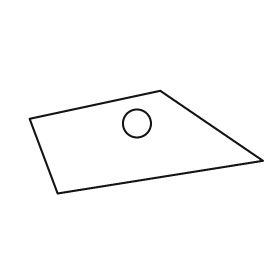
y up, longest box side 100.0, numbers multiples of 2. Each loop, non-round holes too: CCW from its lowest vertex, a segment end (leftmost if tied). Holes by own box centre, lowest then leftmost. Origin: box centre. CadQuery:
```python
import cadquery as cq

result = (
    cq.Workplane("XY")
    .moveTo(-38.0, -22.0)
    .lineTo(50.0, -8.0)
    .lineTo(6.0, 22.0)
    .lineTo(-50.0, 10.0)
    .close()
    .moveTo(-4.0, 8.0)
    .circle(6.0)
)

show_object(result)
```